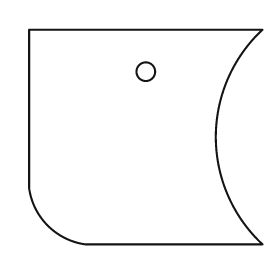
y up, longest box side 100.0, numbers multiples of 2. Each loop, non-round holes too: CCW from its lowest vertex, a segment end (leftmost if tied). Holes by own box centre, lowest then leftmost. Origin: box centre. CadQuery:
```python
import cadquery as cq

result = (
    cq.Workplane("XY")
    .moveTo(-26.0, -46.0)
    .lineTo(50.0, -46.0)
    .threePointArc((30.0, 0.0), (50.0, 46.0))
    .lineTo(-50.0, 46.0)
    .lineTo(-50.0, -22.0)
    .threePointArc((-42.0, -38.0), (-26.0, -46.0))
    .close()
    .moveTo(0.0, 28.0)
    .circle(4.0)
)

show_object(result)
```